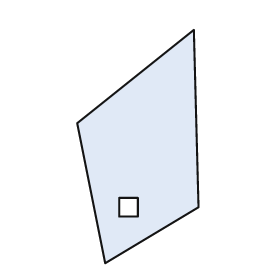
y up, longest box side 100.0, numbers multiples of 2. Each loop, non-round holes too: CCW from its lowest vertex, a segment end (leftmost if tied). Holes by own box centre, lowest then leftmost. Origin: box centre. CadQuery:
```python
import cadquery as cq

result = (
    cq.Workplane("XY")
    .moveTo(-14.0, -50.0)
    .lineTo(26.0, -26.0)
    .lineTo(24.0, 50.0)
    .lineTo(-26.0, 10.0)
    .close()
    .moveTo(-8.0, -30.0)
    .lineTo(0.0, -30.0)
    .lineTo(0.0, -22.0)
    .lineTo(-8.0, -22.0)
    .close()
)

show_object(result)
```